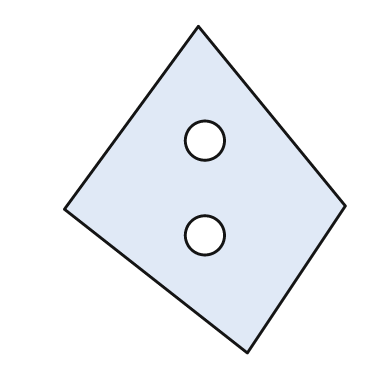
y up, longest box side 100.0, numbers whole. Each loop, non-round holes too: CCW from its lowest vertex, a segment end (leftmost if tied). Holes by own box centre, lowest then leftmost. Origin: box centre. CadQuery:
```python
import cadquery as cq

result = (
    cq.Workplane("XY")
    .moveTo(13.0, -50.0)
    .lineTo(43.0, -5.0)
    .lineTo(-2.0, 50.0)
    .lineTo(-43.0, -6.0)
    .close()
    .moveTo(0.0, -14.0)
    .circle(6.0)
    .moveTo(0.0, 15.0)
    .circle(6.0)
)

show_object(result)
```